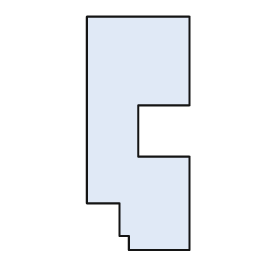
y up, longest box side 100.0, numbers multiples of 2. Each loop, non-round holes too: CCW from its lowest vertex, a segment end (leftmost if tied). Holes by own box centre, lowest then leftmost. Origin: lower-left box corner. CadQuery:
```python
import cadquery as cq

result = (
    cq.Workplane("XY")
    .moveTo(18.0, 0.0)
    .lineTo(44.0, 0.0)
    .lineTo(44.0, 40.0)
    .lineTo(22.0, 40.0)
    .lineTo(22.0, 62.0)
    .lineTo(44.0, 62.0)
    .lineTo(44.0, 100.0)
    .lineTo(0.0, 100.0)
    .lineTo(0.0, 20.0)
    .lineTo(14.0, 20.0)
    .lineTo(14.0, 6.0)
    .lineTo(18.0, 6.0)
    .close()
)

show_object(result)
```